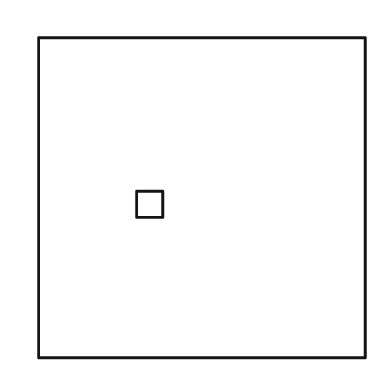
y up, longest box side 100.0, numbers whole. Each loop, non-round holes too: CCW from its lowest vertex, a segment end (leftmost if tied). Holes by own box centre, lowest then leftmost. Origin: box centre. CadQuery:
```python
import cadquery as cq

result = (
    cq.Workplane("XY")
    .moveTo(-50.0, -49.0)
    .lineTo(50.0, -49.0)
    .lineTo(50.0, 49.0)
    .lineTo(-50.0, 49.0)
    .close()
    .moveTo(-20.0, -6.0)
    .lineTo(-12.0, -6.0)
    .lineTo(-12.0, 2.0)
    .lineTo(-20.0, 2.0)
    .close()
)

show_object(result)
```